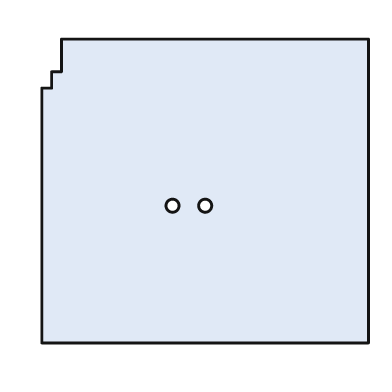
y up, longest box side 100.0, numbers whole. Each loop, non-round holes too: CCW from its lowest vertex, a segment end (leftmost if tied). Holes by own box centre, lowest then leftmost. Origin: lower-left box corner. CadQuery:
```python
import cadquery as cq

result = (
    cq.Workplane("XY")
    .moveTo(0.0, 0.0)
    .lineTo(100.0, 0.0)
    .lineTo(100.0, 93.0)
    .lineTo(6.0, 93.0)
    .lineTo(6.0, 83.0)
    .lineTo(3.0, 83.0)
    .lineTo(3.0, 78.0)
    .lineTo(0.0, 78.0)
    .close()
    .moveTo(40.0, 42.0)
    .circle(2.0)
    .moveTo(50.0, 42.0)
    .circle(2.0)
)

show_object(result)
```